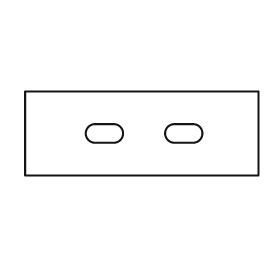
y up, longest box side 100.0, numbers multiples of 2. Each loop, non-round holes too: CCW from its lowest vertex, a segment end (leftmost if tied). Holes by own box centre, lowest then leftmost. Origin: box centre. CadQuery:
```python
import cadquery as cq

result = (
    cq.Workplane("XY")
    .moveTo(-50.0, -18.0)
    .lineTo(50.0, -18.0)
    .lineTo(50.0, 18.0)
    .lineTo(-50.0, 18.0)
    .close()
    .moveTo(-20.0, -4.0)
    .lineTo(-12.0, -4.0)
    .threePointArc((-8.0, 0.0), (-12.0, 4.0))
    .lineTo(-20.0, 4.0)
    .threePointArc((-24.0, 0.0), (-20.0, -4.0))
    .close()
    .moveTo(14.0, -4.0)
    .lineTo(22.0, -4.0)
    .threePointArc((26.0, 0.0), (22.0, 4.0))
    .lineTo(14.0, 4.0)
    .threePointArc((10.0, 0.0), (14.0, -4.0))
    .close()
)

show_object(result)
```